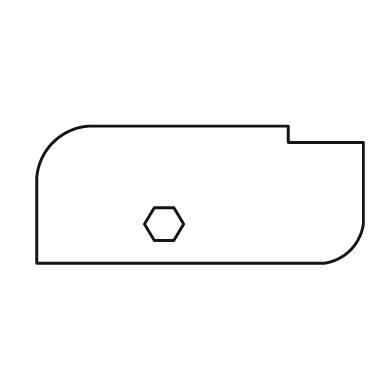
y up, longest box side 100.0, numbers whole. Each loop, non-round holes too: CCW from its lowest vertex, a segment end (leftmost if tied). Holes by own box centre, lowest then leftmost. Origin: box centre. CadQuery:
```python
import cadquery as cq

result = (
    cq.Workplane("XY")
    .moveTo(-50.0, -21.0)
    .lineTo(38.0, -21.0)
    .threePointArc((46.0, -17.0), (50.0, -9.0))
    .lineTo(50.0, 16.0)
    .lineTo(27.0, 16.0)
    .lineTo(27.0, 21.0)
    .lineTo(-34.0, 21.0)
    .threePointArc((-45.0, 16.0), (-50.0, 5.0))
    .close()
    .moveTo(-14.0, -14.0)
    .lineTo(-8.0, -14.0)
    .lineTo(-5.0, -9.0)
    .lineTo(-8.0, -4.0)
    .lineTo(-14.0, -4.0)
    .lineTo(-17.0, -9.0)
    .close()
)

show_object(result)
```